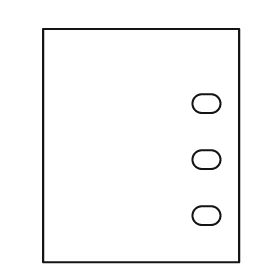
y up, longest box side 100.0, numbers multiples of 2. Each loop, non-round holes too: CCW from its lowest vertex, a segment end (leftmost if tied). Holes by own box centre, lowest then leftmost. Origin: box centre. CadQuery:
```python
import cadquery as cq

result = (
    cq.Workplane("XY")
    .moveTo(-42.0, -50.0)
    .lineTo(42.0, -50.0)
    .lineTo(42.0, 50.0)
    .lineTo(-42.0, 50.0)
    .close()
    .moveTo(26.0, -34.0)
    .lineTo(30.0, -34.0)
    .threePointArc((34.0, -30.0), (30.0, -26.0))
    .lineTo(26.0, -26.0)
    .threePointArc((22.0, -30.0), (26.0, -34.0))
    .close()
    .moveTo(26.0, -10.0)
    .lineTo(30.0, -10.0)
    .threePointArc((34.0, -6.0), (30.0, -2.0))
    .lineTo(26.0, -2.0)
    .threePointArc((22.0, -6.0), (26.0, -10.0))
    .close()
    .moveTo(26.0, 14.0)
    .lineTo(30.0, 14.0)
    .threePointArc((34.0, 18.0), (30.0, 22.0))
    .lineTo(26.0, 22.0)
    .threePointArc((22.0, 18.0), (26.0, 14.0))
    .close()
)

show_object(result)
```